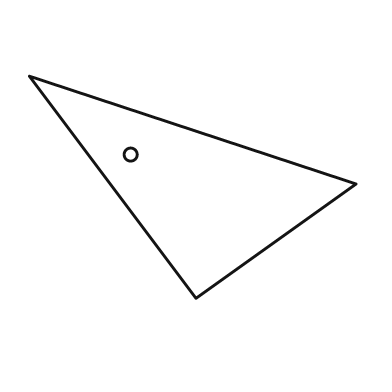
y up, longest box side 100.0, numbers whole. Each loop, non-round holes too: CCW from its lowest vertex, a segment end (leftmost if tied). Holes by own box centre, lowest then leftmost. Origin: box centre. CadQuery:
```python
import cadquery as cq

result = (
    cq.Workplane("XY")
    .moveTo(1.0, -34.0)
    .lineTo(50.0, 1.0)
    .lineTo(-50.0, 34.0)
    .close()
    .moveTo(-19.0, 10.0)
    .circle(2.0)
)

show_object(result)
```